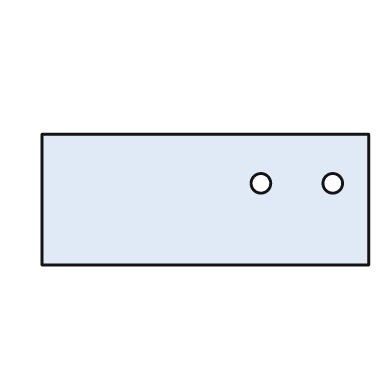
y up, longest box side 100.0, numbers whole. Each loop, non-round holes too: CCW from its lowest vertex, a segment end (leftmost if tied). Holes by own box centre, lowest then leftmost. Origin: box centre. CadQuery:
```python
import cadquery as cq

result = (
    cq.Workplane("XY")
    .moveTo(-50.0, -20.0)
    .lineTo(50.0, -20.0)
    .lineTo(50.0, 20.0)
    .lineTo(-50.0, 20.0)
    .close()
    .moveTo(17.0, 5.0)
    .circle(3.0)
    .moveTo(39.0, 5.0)
    .circle(3.0)
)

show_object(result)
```